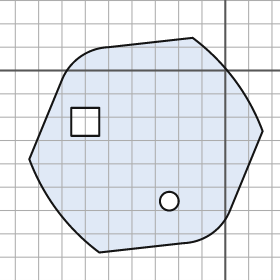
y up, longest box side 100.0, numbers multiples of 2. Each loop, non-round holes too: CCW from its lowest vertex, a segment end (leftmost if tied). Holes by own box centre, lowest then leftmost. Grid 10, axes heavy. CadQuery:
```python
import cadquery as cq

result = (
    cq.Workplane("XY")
    .moveTo(-54.0, -78.0)
    .lineTo(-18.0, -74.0)
    .threePointArc((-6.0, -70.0), (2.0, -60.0))
    .lineTo(16.0, -26.0)
    .threePointArc((4.0, -4.0), (-14.0, 14.0))
    .lineTo(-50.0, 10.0)
    .threePointArc((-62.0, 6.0), (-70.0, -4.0))
    .lineTo(-84.0, -38.0)
    .threePointArc((-72.0, -60.0), (-54.0, -78.0))
    .close()
    .moveTo(-24.0, -56.0)
    .circle(4.0)
    .moveTo(-66.0, -28.0)
    .lineTo(-54.0, -28.0)
    .lineTo(-54.0, -16.0)
    .lineTo(-66.0, -16.0)
    .close()
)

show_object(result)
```